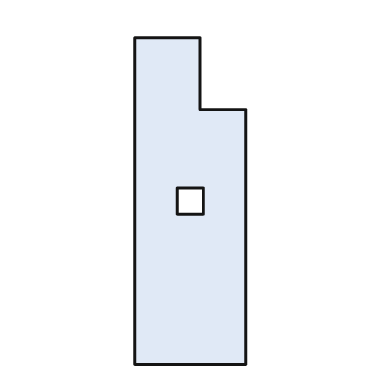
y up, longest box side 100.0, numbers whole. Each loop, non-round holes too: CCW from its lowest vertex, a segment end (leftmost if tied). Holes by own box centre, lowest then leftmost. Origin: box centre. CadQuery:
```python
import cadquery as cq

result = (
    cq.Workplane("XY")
    .moveTo(-17.0, -50.0)
    .lineTo(17.0, -50.0)
    .lineTo(17.0, 28.0)
    .lineTo(3.0, 28.0)
    .lineTo(3.0, 50.0)
    .lineTo(-17.0, 50.0)
    .close()
    .moveTo(-4.0, -4.0)
    .lineTo(4.0, -4.0)
    .lineTo(4.0, 4.0)
    .lineTo(-4.0, 4.0)
    .close()
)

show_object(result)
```